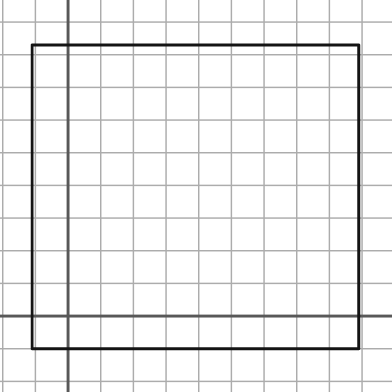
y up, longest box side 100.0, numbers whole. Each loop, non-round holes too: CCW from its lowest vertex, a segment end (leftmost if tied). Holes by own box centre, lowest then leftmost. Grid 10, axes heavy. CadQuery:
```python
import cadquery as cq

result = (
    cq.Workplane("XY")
    .moveTo(-11.0, -10.0)
    .lineTo(89.0, -10.0)
    .lineTo(89.0, 83.0)
    .lineTo(-11.0, 83.0)
    .close()
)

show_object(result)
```